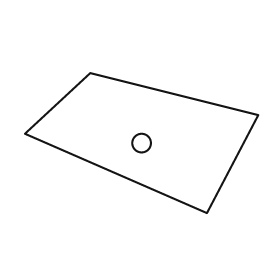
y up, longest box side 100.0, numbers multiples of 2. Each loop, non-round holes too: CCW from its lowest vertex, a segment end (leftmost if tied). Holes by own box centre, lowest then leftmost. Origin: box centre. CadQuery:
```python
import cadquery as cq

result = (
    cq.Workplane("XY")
    .moveTo(28.0, -30.0)
    .lineTo(50.0, 12.0)
    .lineTo(-22.0, 30.0)
    .lineTo(-50.0, 4.0)
    .close()
    .moveTo(0.0, 0.0)
    .circle(4.0)
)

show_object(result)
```